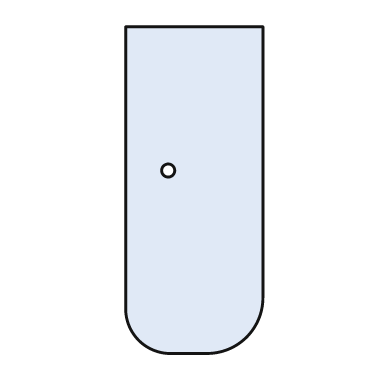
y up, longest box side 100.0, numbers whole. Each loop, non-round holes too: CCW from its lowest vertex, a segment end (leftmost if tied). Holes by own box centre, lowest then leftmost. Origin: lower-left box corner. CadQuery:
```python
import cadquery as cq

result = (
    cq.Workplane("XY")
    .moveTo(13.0, 0.0)
    .lineTo(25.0, 0.0)
    .threePointArc((37.0, 5.0), (42.0, 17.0))
    .lineTo(42.0, 100.0)
    .lineTo(0.0, 100.0)
    .lineTo(0.0, 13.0)
    .threePointArc((4.0, 4.0), (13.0, 0.0))
    .close()
    .moveTo(13.0, 56.0)
    .circle(2.0)
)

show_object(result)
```